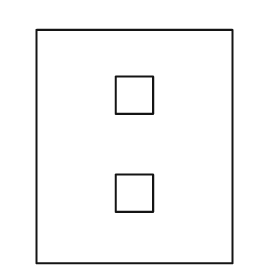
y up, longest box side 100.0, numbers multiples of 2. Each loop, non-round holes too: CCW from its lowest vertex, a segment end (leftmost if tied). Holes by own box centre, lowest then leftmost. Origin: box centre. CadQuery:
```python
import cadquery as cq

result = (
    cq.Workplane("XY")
    .moveTo(-42.0, -50.0)
    .lineTo(42.0, -50.0)
    .lineTo(42.0, 50.0)
    .lineTo(-42.0, 50.0)
    .close()
    .moveTo(-8.0, -28.0)
    .lineTo(8.0, -28.0)
    .lineTo(8.0, -12.0)
    .lineTo(-8.0, -12.0)
    .close()
    .moveTo(-8.0, 14.0)
    .lineTo(8.0, 14.0)
    .lineTo(8.0, 30.0)
    .lineTo(-8.0, 30.0)
    .close()
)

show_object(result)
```